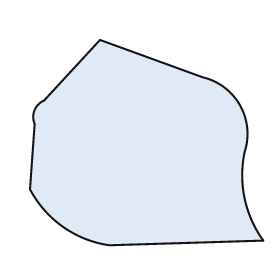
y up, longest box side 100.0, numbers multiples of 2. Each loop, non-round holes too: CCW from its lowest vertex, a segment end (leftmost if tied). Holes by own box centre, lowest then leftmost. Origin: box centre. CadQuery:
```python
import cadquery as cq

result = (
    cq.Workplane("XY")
    .moveTo(-16.0, -44.0)
    .lineTo(50.0, -42.0)
    .threePointArc((42.0, -24.0), (42.0, -4.0))
    .threePointArc((40.0, 16.0), (24.0, 28.0))
    .lineTo(-20.0, 44.0)
    .lineTo(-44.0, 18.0)
    .threePointArc((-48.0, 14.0), (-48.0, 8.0))
    .lineTo(-50.0, -20.0)
    .threePointArc((-36.0, -36.0), (-16.0, -44.0))
    .close()
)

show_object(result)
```